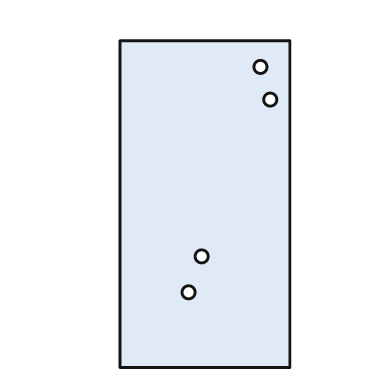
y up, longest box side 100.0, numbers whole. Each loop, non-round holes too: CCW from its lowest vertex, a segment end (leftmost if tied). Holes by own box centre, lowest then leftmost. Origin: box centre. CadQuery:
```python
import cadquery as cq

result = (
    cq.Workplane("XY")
    .moveTo(-26.0, -50.0)
    .lineTo(26.0, -50.0)
    .lineTo(26.0, 50.0)
    .lineTo(-26.0, 50.0)
    .close()
    .moveTo(-5.0, -27.0)
    .circle(2.0)
    .moveTo(-1.0, -16.0)
    .circle(2.0)
    .moveTo(20.0, 32.0)
    .circle(2.0)
    .moveTo(17.0, 42.0)
    .circle(2.0)
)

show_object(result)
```